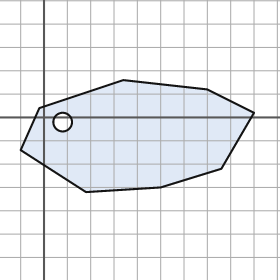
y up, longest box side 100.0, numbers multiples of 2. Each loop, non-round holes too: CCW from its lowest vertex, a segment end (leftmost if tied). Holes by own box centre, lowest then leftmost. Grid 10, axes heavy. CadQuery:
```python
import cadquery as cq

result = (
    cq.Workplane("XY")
    .moveTo(18.0, -32.0)
    .lineTo(50.0, -30.0)
    .lineTo(76.0, -22.0)
    .lineTo(90.0, 2.0)
    .lineTo(70.0, 12.0)
    .lineTo(34.0, 16.0)
    .lineTo(-2.0, 4.0)
    .lineTo(-10.0, -14.0)
    .close()
    .moveTo(8.0, -2.0)
    .circle(4.0)
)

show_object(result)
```